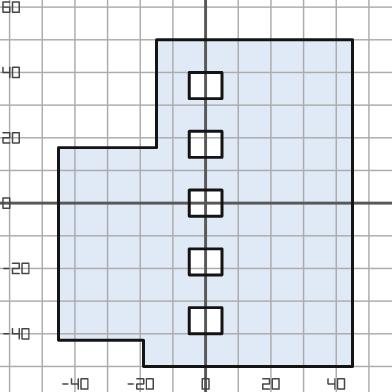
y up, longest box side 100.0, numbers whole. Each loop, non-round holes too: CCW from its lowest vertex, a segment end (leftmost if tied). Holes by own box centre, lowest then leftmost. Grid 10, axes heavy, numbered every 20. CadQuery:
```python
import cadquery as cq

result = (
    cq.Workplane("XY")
    .moveTo(-19.0, -50.0)
    .lineTo(45.0, -50.0)
    .lineTo(45.0, 50.0)
    .lineTo(-15.0, 50.0)
    .lineTo(-15.0, 17.0)
    .lineTo(-45.0, 17.0)
    .lineTo(-45.0, -42.0)
    .lineTo(-19.0, -42.0)
    .close()
    .moveTo(-5.0, -40.0)
    .lineTo(5.0, -40.0)
    .lineTo(5.0, -32.0)
    .lineTo(-5.0, -32.0)
    .close()
    .moveTo(-5.0, -22.0)
    .lineTo(5.0, -22.0)
    .lineTo(5.0, -14.0)
    .lineTo(-5.0, -14.0)
    .close()
    .moveTo(-5.0, -4.0)
    .lineTo(5.0, -4.0)
    .lineTo(5.0, 4.0)
    .lineTo(-5.0, 4.0)
    .close()
    .moveTo(-5.0, 14.0)
    .lineTo(5.0, 14.0)
    .lineTo(5.0, 22.0)
    .lineTo(-5.0, 22.0)
    .close()
    .moveTo(-5.0, 32.0)
    .lineTo(5.0, 32.0)
    .lineTo(5.0, 40.0)
    .lineTo(-5.0, 40.0)
    .close()
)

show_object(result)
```